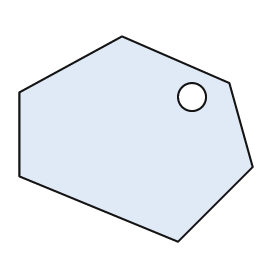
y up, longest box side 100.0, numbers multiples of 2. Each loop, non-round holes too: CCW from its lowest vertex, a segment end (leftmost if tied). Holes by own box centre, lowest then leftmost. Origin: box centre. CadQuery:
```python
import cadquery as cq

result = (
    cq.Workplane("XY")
    .moveTo(18.0, -44.0)
    .lineTo(50.0, -12.0)
    .lineTo(40.0, 24.0)
    .lineTo(-6.0, 44.0)
    .lineTo(-50.0, 20.0)
    .lineTo(-50.0, -16.0)
    .close()
    .moveTo(24.0, 18.0)
    .circle(6.0)
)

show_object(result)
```